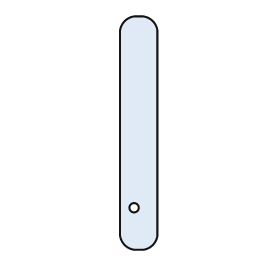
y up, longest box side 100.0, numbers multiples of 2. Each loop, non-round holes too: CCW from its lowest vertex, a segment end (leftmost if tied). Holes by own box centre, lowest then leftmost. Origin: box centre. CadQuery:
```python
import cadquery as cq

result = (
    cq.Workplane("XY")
    .moveTo(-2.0, -50.0)
    .lineTo(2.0, -50.0)
    .threePointArc((6.0, -48.0), (8.0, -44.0))
    .lineTo(8.0, 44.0)
    .threePointArc((6.0, 48.0), (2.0, 50.0))
    .lineTo(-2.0, 50.0)
    .threePointArc((-6.0, 48.0), (-8.0, 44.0))
    .lineTo(-8.0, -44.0)
    .threePointArc((-6.0, -48.0), (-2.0, -50.0))
    .close()
    .moveTo(-2.0, -32.0)
    .circle(2.0)
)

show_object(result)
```